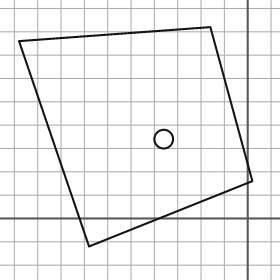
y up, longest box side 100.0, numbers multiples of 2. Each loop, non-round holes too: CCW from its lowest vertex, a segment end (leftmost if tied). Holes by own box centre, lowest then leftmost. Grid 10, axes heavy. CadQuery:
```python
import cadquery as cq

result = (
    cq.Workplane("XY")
    .moveTo(-68.0, -12.0)
    .lineTo(2.0, 16.0)
    .lineTo(-16.0, 82.0)
    .lineTo(-98.0, 76.0)
    .close()
    .moveTo(-36.0, 34.0)
    .circle(4.0)
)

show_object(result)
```